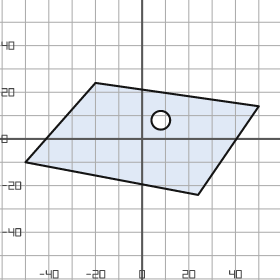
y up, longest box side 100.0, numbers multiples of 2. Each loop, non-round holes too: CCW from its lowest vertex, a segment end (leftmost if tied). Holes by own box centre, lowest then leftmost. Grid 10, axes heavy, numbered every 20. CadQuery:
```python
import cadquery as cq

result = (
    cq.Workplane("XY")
    .moveTo(24.0, -24.0)
    .lineTo(50.0, 14.0)
    .lineTo(-20.0, 24.0)
    .lineTo(-50.0, -10.0)
    .close()
    .moveTo(8.0, 8.0)
    .circle(4.0)
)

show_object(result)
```